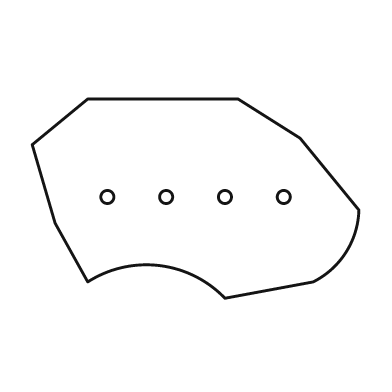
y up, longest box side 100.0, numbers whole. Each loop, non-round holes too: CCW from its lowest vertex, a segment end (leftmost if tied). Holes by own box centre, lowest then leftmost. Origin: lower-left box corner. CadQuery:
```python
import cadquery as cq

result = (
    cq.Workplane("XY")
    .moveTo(59.0, 0.0)
    .lineTo(86.0, 5.0)
    .threePointArc((96.0, 14.0), (100.0, 27.0))
    .lineTo(82.0, 49.0)
    .lineTo(63.0, 61.0)
    .lineTo(17.0, 61.0)
    .lineTo(0.0, 47.0)
    .lineTo(7.0, 23.0)
    .lineTo(17.0, 5.0)
    .threePointArc((39.0, 10.0), (59.0, 0.0))
    .close()
    .moveTo(23.0, 31.0)
    .circle(2.0)
    .moveTo(41.0, 31.0)
    .circle(2.0)
    .moveTo(59.0, 31.0)
    .circle(2.0)
    .moveTo(77.0, 31.0)
    .circle(2.0)
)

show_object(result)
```